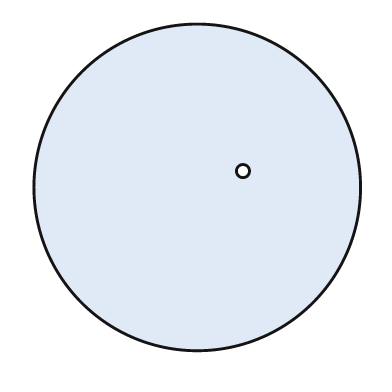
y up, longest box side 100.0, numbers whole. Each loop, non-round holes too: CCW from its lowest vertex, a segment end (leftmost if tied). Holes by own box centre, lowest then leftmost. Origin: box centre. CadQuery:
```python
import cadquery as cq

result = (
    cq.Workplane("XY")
    .moveTo(0.0, 0.0)
    .circle(50.0)
    .moveTo(14.0, 5.0)
    .circle(2.0)
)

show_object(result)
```